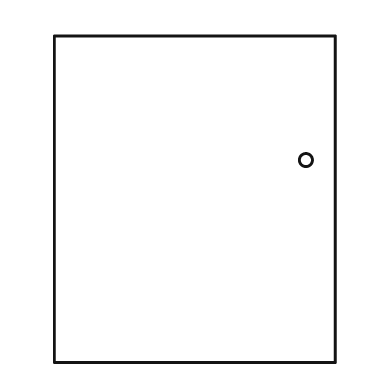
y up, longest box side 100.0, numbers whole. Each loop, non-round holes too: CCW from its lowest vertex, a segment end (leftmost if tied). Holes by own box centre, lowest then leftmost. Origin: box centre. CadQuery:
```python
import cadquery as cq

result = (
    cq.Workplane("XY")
    .moveTo(-43.0, -50.0)
    .lineTo(43.0, -50.0)
    .lineTo(43.0, 50.0)
    .lineTo(-43.0, 50.0)
    .close()
    .moveTo(34.0, 12.0)
    .circle(2.0)
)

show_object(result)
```